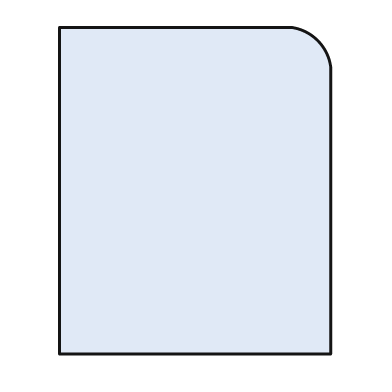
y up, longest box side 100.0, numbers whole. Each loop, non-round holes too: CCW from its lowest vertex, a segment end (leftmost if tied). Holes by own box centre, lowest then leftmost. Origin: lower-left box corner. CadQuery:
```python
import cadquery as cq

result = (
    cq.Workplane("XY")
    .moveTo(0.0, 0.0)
    .lineTo(83.0, 0.0)
    .lineTo(83.0, 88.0)
    .threePointArc((79.0, 96.0), (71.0, 100.0))
    .lineTo(0.0, 100.0)
    .close()
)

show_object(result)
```